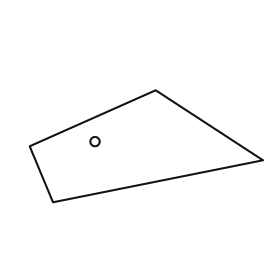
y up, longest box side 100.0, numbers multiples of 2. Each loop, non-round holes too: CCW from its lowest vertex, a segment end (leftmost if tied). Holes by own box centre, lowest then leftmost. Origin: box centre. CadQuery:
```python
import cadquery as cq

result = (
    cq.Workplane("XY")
    .moveTo(-40.0, -24.0)
    .lineTo(50.0, -6.0)
    .lineTo(4.0, 24.0)
    .lineTo(-50.0, 0.0)
    .close()
    .moveTo(-22.0, 2.0)
    .circle(2.0)
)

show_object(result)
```